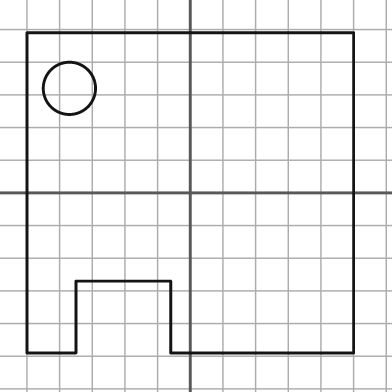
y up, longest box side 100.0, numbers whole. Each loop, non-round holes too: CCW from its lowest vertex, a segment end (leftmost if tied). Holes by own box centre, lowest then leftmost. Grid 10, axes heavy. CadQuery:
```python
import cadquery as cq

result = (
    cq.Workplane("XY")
    .moveTo(-50.0, -49.0)
    .lineTo(-35.0, -49.0)
    .lineTo(-35.0, -27.0)
    .lineTo(-6.0, -27.0)
    .lineTo(-6.0, -49.0)
    .lineTo(50.0, -49.0)
    .lineTo(50.0, 49.0)
    .lineTo(-50.0, 49.0)
    .close()
    .moveTo(-37.0, 32.0)
    .circle(8.0)
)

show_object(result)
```